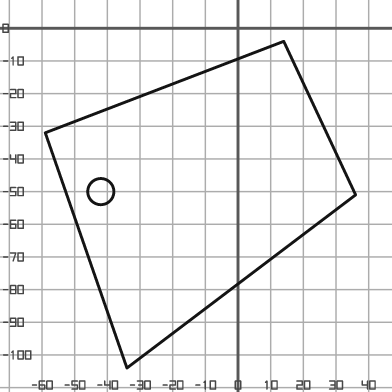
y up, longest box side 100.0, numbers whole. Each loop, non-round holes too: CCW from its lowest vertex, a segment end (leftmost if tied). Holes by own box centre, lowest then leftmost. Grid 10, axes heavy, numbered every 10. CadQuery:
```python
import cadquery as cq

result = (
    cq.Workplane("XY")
    .moveTo(-34.0, -104.0)
    .lineTo(36.0, -51.0)
    .lineTo(14.0, -4.0)
    .lineTo(-59.0, -32.0)
    .close()
    .moveTo(-42.0, -50.0)
    .circle(4.0)
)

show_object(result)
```